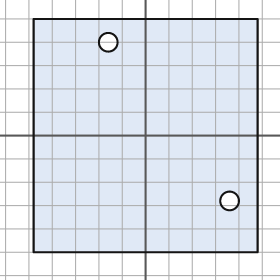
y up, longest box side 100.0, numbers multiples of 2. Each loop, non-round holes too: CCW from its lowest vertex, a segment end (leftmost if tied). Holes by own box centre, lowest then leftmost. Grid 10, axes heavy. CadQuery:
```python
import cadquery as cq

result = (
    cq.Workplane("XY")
    .moveTo(-48.0, -50.0)
    .lineTo(48.0, -50.0)
    .lineTo(48.0, 50.0)
    .lineTo(-48.0, 50.0)
    .close()
    .moveTo(36.0, -28.0)
    .circle(4.0)
    .moveTo(-16.0, 40.0)
    .circle(4.0)
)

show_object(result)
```